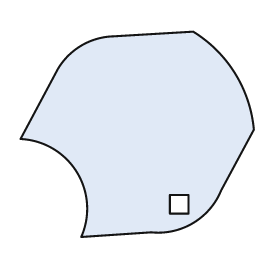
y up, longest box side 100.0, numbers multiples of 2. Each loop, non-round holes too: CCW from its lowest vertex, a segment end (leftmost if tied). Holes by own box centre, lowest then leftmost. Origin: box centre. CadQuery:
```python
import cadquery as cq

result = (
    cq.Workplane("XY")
    .moveTo(-24.0, -44.0)
    .lineTo(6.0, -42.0)
    .threePointArc((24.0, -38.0), (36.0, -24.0))
    .lineTo(50.0, 2.0)
    .threePointArc((42.0, 26.0), (24.0, 44.0))
    .lineTo(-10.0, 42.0)
    .threePointArc((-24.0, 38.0), (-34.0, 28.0))
    .lineTo(-50.0, -2.0)
    .threePointArc((-26.0, -16.0), (-24.0, -44.0))
    .close()
    .moveTo(14.0, -34.0)
    .lineTo(22.0, -34.0)
    .lineTo(22.0, -26.0)
    .lineTo(14.0, -26.0)
    .close()
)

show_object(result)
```